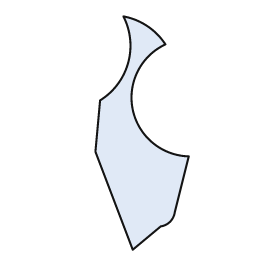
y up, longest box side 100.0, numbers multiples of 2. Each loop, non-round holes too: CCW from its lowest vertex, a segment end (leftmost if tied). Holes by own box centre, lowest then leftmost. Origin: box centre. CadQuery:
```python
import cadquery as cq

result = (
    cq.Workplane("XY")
    .moveTo(-4.0, -50.0)
    .lineTo(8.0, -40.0)
    .threePointArc((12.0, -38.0), (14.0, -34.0))
    .lineTo(20.0, -10.0)
    .threePointArc((-4.0, 10.0), (10.0, 38.0))
    .threePointArc((2.0, 46.0), (-8.0, 50.0))
    .threePointArc((-6.0, 30.0), (-18.0, 14.0))
    .lineTo(-20.0, -8.0)
    .close()
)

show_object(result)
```